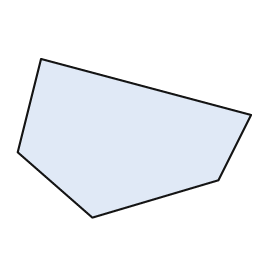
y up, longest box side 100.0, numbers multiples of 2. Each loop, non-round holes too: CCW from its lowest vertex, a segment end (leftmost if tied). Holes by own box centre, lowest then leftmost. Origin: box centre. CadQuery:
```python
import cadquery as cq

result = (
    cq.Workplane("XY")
    .moveTo(-18.0, -34.0)
    .lineTo(36.0, -18.0)
    .lineTo(50.0, 10.0)
    .lineTo(-40.0, 34.0)
    .lineTo(-50.0, -6.0)
    .close()
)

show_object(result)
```